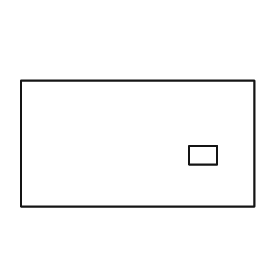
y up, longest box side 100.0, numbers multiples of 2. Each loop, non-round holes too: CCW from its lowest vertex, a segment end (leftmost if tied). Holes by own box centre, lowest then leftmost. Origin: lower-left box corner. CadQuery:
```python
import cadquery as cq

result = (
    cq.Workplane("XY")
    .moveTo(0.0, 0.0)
    .lineTo(100.0, 0.0)
    .lineTo(100.0, 54.0)
    .lineTo(0.0, 54.0)
    .close()
    .moveTo(72.0, 18.0)
    .lineTo(84.0, 18.0)
    .lineTo(84.0, 26.0)
    .lineTo(72.0, 26.0)
    .close()
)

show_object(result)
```